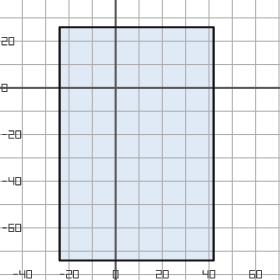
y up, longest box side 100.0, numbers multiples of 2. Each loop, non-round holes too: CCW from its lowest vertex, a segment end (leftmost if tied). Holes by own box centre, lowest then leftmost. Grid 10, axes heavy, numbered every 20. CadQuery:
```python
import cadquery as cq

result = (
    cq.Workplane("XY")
    .moveTo(-24.0, -74.0)
    .lineTo(42.0, -74.0)
    .lineTo(42.0, 26.0)
    .lineTo(-24.0, 26.0)
    .close()
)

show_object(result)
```